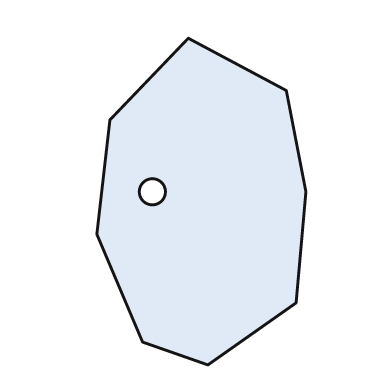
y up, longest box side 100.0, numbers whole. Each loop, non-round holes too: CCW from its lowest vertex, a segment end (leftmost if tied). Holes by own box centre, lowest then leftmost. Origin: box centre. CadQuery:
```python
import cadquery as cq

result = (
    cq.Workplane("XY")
    .moveTo(2.0, -50.0)
    .lineTo(29.0, -31.0)
    .lineTo(32.0, 3.0)
    .lineTo(26.0, 34.0)
    .lineTo(-4.0, 50.0)
    .lineTo(-28.0, 25.0)
    .lineTo(-32.0, -10.0)
    .lineTo(-18.0, -43.0)
    .close()
    .moveTo(-15.0, 3.0)
    .circle(4.0)
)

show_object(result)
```